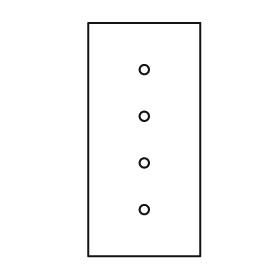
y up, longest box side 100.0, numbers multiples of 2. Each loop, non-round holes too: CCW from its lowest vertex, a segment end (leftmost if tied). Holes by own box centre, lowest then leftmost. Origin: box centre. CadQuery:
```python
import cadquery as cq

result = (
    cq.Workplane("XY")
    .moveTo(-24.0, -50.0)
    .lineTo(24.0, -50.0)
    .lineTo(24.0, 50.0)
    .lineTo(-24.0, 50.0)
    .close()
    .moveTo(0.0, -30.0)
    .circle(2.0)
    .moveTo(0.0, -10.0)
    .circle(2.0)
    .moveTo(0.0, 10.0)
    .circle(2.0)
    .moveTo(0.0, 30.0)
    .circle(2.0)
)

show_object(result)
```